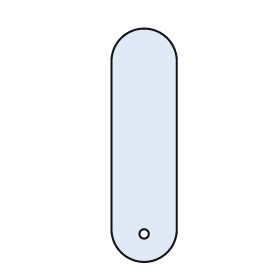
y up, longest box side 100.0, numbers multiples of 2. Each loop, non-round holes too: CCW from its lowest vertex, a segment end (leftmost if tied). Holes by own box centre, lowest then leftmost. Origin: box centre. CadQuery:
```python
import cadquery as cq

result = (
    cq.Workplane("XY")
    .moveTo(-14.0, -36.0)
    .threePointArc((0.0, -50.0), (14.0, -36.0))
    .lineTo(14.0, 36.0)
    .threePointArc((0.0, 50.0), (-14.0, 36.0))
    .close()
    .moveTo(0.0, -38.0)
    .circle(2.0)
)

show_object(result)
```